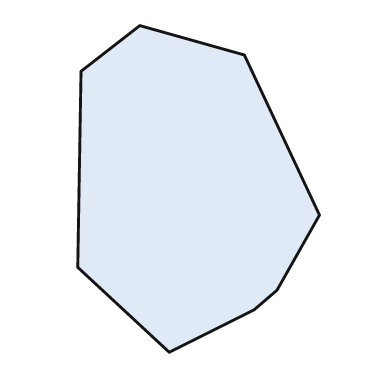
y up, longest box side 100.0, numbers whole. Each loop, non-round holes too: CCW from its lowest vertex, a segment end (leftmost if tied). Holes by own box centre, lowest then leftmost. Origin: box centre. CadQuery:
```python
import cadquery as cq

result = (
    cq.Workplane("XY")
    .moveTo(-9.0, -50.0)
    .lineTo(17.0, -37.0)
    .lineTo(24.0, -31.0)
    .lineTo(37.0, -8.0)
    .lineTo(14.0, 41.0)
    .lineTo(-18.0, 50.0)
    .lineTo(-36.0, 36.0)
    .lineTo(-37.0, -24.0)
    .close()
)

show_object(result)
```